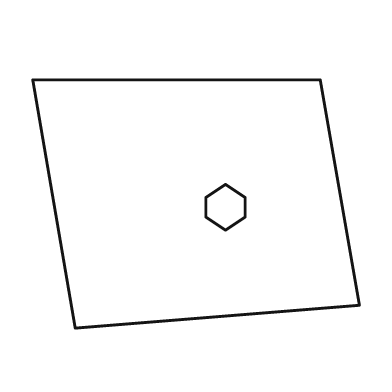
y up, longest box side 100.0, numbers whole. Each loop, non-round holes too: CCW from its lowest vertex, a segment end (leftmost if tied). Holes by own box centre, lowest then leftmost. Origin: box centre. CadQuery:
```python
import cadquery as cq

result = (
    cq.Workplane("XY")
    .moveTo(-37.0, -38.0)
    .lineTo(50.0, -31.0)
    .lineTo(38.0, 38.0)
    .lineTo(-50.0, 38.0)
    .close()
    .moveTo(9.0, -8.0)
    .lineTo(15.0, -4.0)
    .lineTo(15.0, 2.0)
    .lineTo(9.0, 6.0)
    .lineTo(3.0, 2.0)
    .lineTo(3.0, -4.0)
    .close()
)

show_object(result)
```